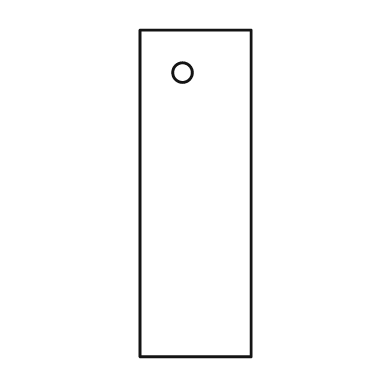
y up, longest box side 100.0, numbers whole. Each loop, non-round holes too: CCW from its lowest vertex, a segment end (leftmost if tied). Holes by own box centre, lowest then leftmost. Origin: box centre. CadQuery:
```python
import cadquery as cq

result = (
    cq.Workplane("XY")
    .moveTo(-17.0, -50.0)
    .lineTo(17.0, -50.0)
    .lineTo(17.0, 50.0)
    .lineTo(-17.0, 50.0)
    .close()
    .moveTo(-4.0, 37.0)
    .circle(3.0)
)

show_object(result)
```